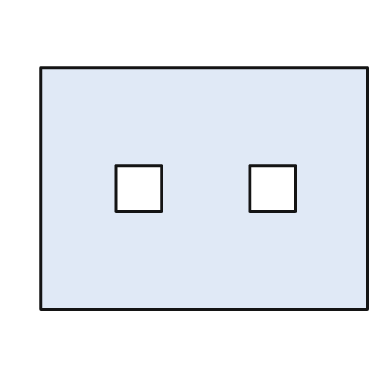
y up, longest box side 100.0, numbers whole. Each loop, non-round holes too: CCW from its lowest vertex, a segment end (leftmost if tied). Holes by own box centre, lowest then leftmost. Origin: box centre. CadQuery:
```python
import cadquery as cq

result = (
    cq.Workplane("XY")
    .moveTo(-50.0, -37.0)
    .lineTo(50.0, -37.0)
    .lineTo(50.0, 37.0)
    .lineTo(-50.0, 37.0)
    .close()
    .moveTo(-27.0, -7.0)
    .lineTo(-13.0, -7.0)
    .lineTo(-13.0, 7.0)
    .lineTo(-27.0, 7.0)
    .close()
    .moveTo(14.0, -7.0)
    .lineTo(28.0, -7.0)
    .lineTo(28.0, 7.0)
    .lineTo(14.0, 7.0)
    .close()
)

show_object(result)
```